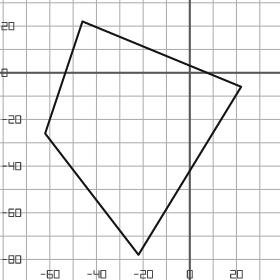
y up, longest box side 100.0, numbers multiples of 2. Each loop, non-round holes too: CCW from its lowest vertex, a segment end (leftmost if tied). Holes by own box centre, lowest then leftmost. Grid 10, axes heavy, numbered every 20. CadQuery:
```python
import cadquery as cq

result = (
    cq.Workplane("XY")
    .moveTo(-22.0, -78.0)
    .lineTo(22.0, -6.0)
    .lineTo(-46.0, 22.0)
    .lineTo(-62.0, -26.0)
    .close()
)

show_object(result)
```